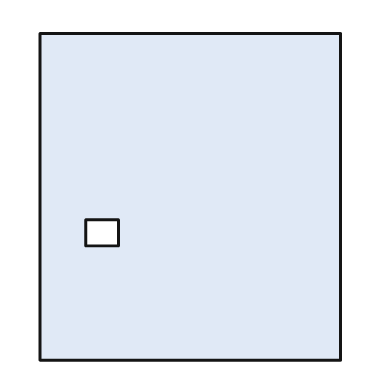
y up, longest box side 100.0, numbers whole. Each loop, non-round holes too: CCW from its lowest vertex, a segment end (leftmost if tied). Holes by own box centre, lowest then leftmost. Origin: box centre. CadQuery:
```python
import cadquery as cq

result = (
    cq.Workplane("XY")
    .moveTo(-46.0, -50.0)
    .lineTo(46.0, -50.0)
    .lineTo(46.0, 50.0)
    .lineTo(-46.0, 50.0)
    .close()
    .moveTo(-32.0, -15.0)
    .lineTo(-22.0, -15.0)
    .lineTo(-22.0, -7.0)
    .lineTo(-32.0, -7.0)
    .close()
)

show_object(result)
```